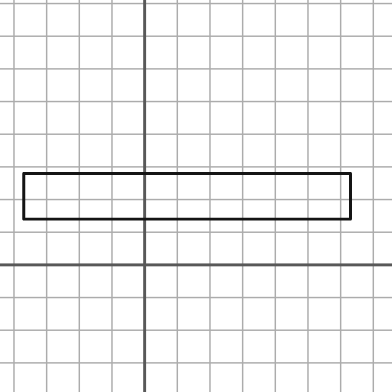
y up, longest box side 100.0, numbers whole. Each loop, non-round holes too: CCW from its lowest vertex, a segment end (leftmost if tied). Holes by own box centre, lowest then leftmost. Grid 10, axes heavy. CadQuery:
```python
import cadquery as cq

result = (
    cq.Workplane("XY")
    .moveTo(-37.0, 14.0)
    .lineTo(63.0, 14.0)
    .lineTo(63.0, 28.0)
    .lineTo(-37.0, 28.0)
    .close()
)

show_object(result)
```